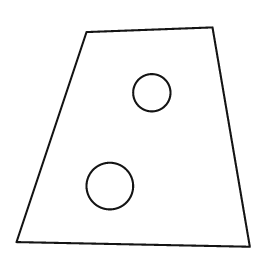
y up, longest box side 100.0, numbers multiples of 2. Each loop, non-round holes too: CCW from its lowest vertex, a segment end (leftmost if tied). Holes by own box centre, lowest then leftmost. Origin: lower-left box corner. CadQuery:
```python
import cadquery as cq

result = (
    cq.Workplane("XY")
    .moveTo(100.0, 0.0)
    .lineTo(84.0, 94.0)
    .lineTo(30.0, 92.0)
    .lineTo(0.0, 2.0)
    .close()
    .moveTo(40.0, 26.0)
    .circle(10.0)
    .moveTo(58.0, 66.0)
    .circle(8.0)
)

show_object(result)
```